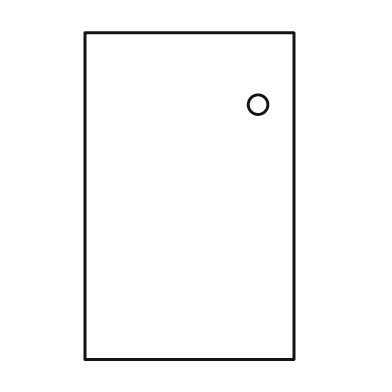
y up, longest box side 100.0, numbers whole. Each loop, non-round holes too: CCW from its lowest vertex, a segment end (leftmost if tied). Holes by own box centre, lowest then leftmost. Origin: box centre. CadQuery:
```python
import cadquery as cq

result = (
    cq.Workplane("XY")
    .moveTo(-32.0, -50.0)
    .lineTo(32.0, -50.0)
    .lineTo(32.0, 50.0)
    .lineTo(-32.0, 50.0)
    .close()
    .moveTo(21.0, 28.0)
    .circle(3.0)
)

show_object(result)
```